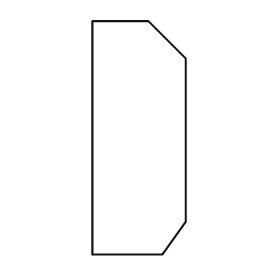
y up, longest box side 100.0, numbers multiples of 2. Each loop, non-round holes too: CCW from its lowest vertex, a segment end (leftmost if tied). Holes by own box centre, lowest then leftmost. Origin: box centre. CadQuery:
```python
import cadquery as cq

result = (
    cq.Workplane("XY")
    .moveTo(-20.0, -50.0)
    .lineTo(10.0, -50.0)
    .lineTo(20.0, -36.0)
    .lineTo(20.0, 34.0)
    .lineTo(4.0, 50.0)
    .lineTo(-20.0, 50.0)
    .close()
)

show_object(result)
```